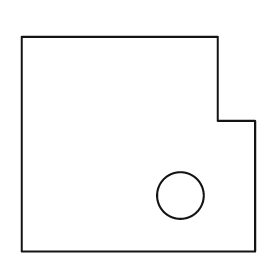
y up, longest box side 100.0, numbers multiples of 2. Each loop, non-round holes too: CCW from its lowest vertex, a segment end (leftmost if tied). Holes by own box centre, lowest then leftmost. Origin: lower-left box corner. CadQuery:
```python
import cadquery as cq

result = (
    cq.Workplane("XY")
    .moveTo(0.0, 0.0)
    .lineTo(100.0, 0.0)
    .lineTo(100.0, 56.0)
    .lineTo(84.0, 56.0)
    .lineTo(84.0, 92.0)
    .lineTo(0.0, 92.0)
    .close()
    .moveTo(68.0, 24.0)
    .circle(10.0)
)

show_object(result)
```